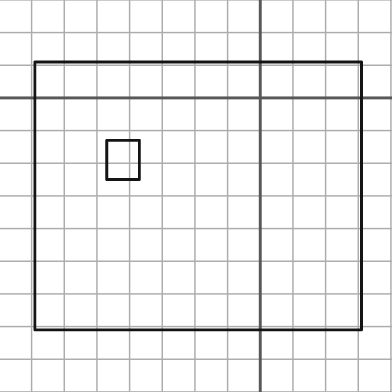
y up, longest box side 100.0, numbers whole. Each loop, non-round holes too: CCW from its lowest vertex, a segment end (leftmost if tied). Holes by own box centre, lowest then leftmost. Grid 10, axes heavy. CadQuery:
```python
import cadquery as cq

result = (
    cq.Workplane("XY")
    .moveTo(-69.0, -71.0)
    .lineTo(31.0, -71.0)
    .lineTo(31.0, 11.0)
    .lineTo(-69.0, 11.0)
    .close()
    .moveTo(-47.0, -25.0)
    .lineTo(-37.0, -25.0)
    .lineTo(-37.0, -13.0)
    .lineTo(-47.0, -13.0)
    .close()
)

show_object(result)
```